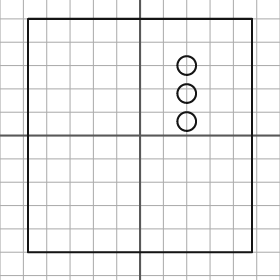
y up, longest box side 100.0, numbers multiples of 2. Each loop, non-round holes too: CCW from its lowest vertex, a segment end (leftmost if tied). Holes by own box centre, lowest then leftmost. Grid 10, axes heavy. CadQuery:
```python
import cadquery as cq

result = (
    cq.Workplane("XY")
    .moveTo(-48.0, -50.0)
    .lineTo(48.0, -50.0)
    .lineTo(48.0, 50.0)
    .lineTo(-48.0, 50.0)
    .close()
    .moveTo(20.0, 6.0)
    .circle(4.0)
    .moveTo(20.0, 18.0)
    .circle(4.0)
    .moveTo(20.0, 30.0)
    .circle(4.0)
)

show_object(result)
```